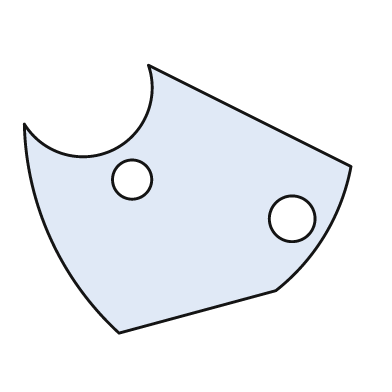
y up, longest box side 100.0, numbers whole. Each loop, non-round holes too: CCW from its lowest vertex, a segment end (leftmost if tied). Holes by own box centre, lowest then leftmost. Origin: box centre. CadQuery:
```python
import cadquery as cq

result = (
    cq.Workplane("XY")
    .moveTo(-21.0, -41.0)
    .lineTo(27.0, -28.0)
    .threePointArc((42.0, -11.0), (50.0, 10.0))
    .lineTo(-12.0, 41.0)
    .threePointArc((-23.0, 15.0), (-50.0, 23.0))
    .threePointArc((-42.0, -12.0), (-21.0, -41.0))
    .close()
    .moveTo(32.0, -6.0)
    .circle(7.0)
    .moveTo(-17.0, 6.0)
    .circle(6.0)
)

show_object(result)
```